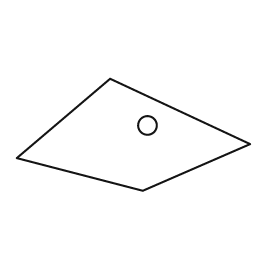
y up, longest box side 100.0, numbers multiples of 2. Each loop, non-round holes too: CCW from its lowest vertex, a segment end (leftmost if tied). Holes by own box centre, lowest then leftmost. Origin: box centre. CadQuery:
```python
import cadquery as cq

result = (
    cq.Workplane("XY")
    .moveTo(4.0, -24.0)
    .lineTo(50.0, -4.0)
    .lineTo(-10.0, 24.0)
    .lineTo(-50.0, -10.0)
    .close()
    .moveTo(6.0, 4.0)
    .circle(4.0)
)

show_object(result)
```